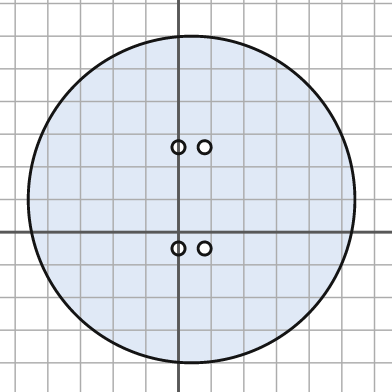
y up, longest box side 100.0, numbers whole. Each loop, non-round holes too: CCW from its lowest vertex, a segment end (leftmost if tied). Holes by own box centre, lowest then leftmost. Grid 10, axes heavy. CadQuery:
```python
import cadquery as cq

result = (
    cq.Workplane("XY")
    .moveTo(4.0, 10.0)
    .circle(50.0)
    .moveTo(0.0, -5.0)
    .circle(2.0)
    .moveTo(8.0, -5.0)
    .circle(2.0)
    .moveTo(0.0, 26.0)
    .circle(2.0)
    .moveTo(8.0, 26.0)
    .circle(2.0)
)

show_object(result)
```